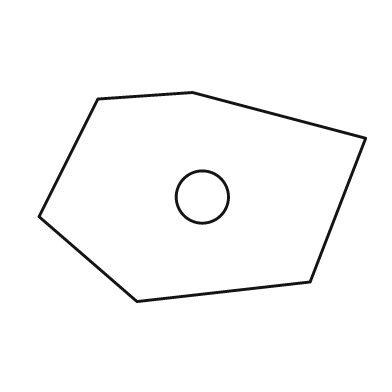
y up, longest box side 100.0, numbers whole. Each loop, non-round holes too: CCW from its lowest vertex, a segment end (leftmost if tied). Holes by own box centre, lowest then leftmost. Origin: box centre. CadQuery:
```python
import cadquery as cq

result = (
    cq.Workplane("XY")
    .moveTo(-20.0, -32.0)
    .lineTo(33.0, -26.0)
    .lineTo(50.0, 18.0)
    .lineTo(-3.0, 32.0)
    .lineTo(-32.0, 30.0)
    .lineTo(-50.0, -6.0)
    .close()
    .moveTo(0.0, 0.0)
    .circle(8.0)
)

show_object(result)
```